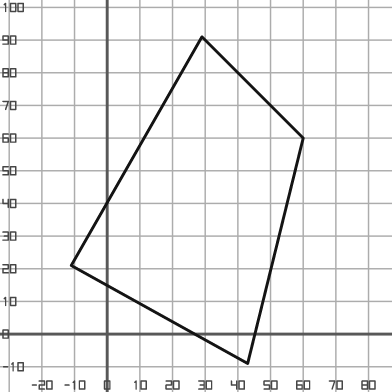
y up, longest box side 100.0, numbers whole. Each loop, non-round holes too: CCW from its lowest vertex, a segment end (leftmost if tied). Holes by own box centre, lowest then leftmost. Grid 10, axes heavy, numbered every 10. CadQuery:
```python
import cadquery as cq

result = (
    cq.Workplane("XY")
    .moveTo(43.0, -9.0)
    .lineTo(60.0, 60.0)
    .lineTo(29.0, 91.0)
    .lineTo(-11.0, 21.0)
    .close()
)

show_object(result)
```